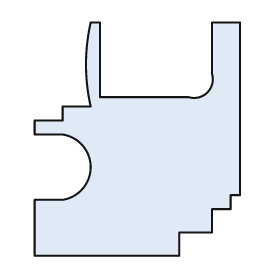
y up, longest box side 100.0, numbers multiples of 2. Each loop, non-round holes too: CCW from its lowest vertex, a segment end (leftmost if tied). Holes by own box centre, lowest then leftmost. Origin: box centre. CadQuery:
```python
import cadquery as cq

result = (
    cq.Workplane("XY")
    .moveTo(-44.0, -50.0)
    .lineTo(18.0, -50.0)
    .lineTo(18.0, -40.0)
    .lineTo(32.0, -40.0)
    .lineTo(32.0, -30.0)
    .lineTo(40.0, -30.0)
    .lineTo(40.0, -24.0)
    .lineTo(44.0, -24.0)
    .lineTo(44.0, 50.0)
    .lineTo(32.0, 50.0)
    .lineTo(32.0, 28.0)
    .threePointArc((30.0, 20.0), (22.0, 18.0))
    .lineTo(-16.0, 18.0)
    .lineTo(-16.0, 50.0)
    .lineTo(-20.0, 50.0)
    .threePointArc((-22.0, 32.0), (-20.0, 14.0))
    .lineTo(-32.0, 14.0)
    .lineTo(-32.0, 8.0)
    .lineTo(-44.0, 8.0)
    .lineTo(-44.0, 2.0)
    .lineTo(-32.0, 2.0)
    .threePointArc((-20.0, -12.0), (-32.0, -26.0))
    .lineTo(-44.0, -26.0)
    .close()
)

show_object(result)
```